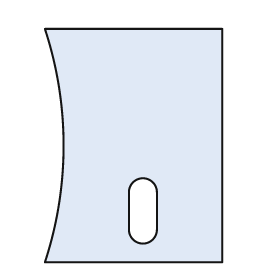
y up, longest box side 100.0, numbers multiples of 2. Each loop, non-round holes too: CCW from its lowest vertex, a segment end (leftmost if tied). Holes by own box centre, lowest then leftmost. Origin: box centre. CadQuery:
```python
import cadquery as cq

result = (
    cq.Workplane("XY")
    .moveTo(-38.0, -50.0)
    .lineTo(38.0, -50.0)
    .lineTo(38.0, 50.0)
    .lineTo(-38.0, 50.0)
    .threePointArc((-30.0, 0.0), (-38.0, -50.0))
    .close()
    .moveTo(-2.0, -36.0)
    .threePointArc((4.0, -42.0), (10.0, -36.0))
    .lineTo(10.0, -20.0)
    .threePointArc((4.0, -14.0), (-2.0, -20.0))
    .close()
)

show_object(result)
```